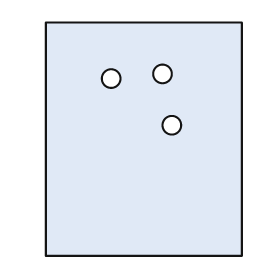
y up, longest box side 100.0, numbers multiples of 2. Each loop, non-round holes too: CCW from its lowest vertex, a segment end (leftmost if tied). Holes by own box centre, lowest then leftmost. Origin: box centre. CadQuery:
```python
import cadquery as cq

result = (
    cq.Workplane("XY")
    .moveTo(-42.0, -50.0)
    .lineTo(42.0, -50.0)
    .lineTo(42.0, 50.0)
    .lineTo(-42.0, 50.0)
    .close()
    .moveTo(12.0, 6.0)
    .circle(4.0)
    .moveTo(-14.0, 26.0)
    .circle(4.0)
    .moveTo(8.0, 28.0)
    .circle(4.0)
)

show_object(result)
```